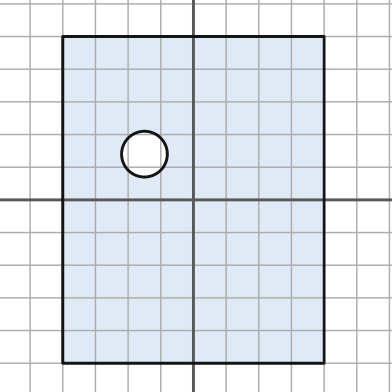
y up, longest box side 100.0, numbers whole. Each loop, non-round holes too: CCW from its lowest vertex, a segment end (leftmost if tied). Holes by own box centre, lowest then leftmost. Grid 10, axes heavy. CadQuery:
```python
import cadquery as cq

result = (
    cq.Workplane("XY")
    .moveTo(-40.0, -50.0)
    .lineTo(40.0, -50.0)
    .lineTo(40.0, 50.0)
    .lineTo(-40.0, 50.0)
    .close()
    .moveTo(-15.0, 14.0)
    .circle(7.0)
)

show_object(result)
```